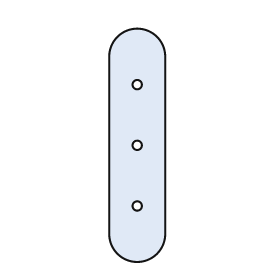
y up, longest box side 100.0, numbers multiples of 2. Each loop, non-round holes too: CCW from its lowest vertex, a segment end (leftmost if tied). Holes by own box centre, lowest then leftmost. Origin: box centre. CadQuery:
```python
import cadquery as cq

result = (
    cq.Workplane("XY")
    .moveTo(-12.0, -38.0)
    .threePointArc((0.0, -50.0), (12.0, -38.0))
    .lineTo(12.0, 38.0)
    .threePointArc((0.0, 50.0), (-12.0, 38.0))
    .close()
    .moveTo(0.0, -26.0)
    .circle(2.0)
    .moveTo(0.0, 0.0)
    .circle(2.0)
    .moveTo(0.0, 26.0)
    .circle(2.0)
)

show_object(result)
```